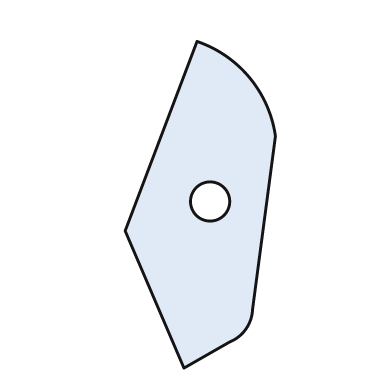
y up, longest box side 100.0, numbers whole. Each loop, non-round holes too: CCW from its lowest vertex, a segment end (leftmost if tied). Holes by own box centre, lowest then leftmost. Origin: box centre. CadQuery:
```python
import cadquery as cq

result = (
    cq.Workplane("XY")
    .moveTo(-5.0, -50.0)
    .lineTo(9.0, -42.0)
    .threePointArc((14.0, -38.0), (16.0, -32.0))
    .lineTo(23.0, 21.0)
    .threePointArc((15.0, 39.0), (-1.0, 50.0))
    .lineTo(-23.0, -8.0)
    .close()
    .moveTo(3.0, 1.0)
    .circle(6.0)
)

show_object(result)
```